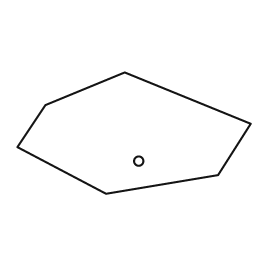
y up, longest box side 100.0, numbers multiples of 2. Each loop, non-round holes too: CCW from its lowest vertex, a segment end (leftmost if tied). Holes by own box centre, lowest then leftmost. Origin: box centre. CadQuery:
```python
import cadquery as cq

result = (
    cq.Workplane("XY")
    .moveTo(-12.0, -26.0)
    .lineTo(36.0, -18.0)
    .lineTo(50.0, 4.0)
    .lineTo(-4.0, 26.0)
    .lineTo(-38.0, 12.0)
    .lineTo(-50.0, -6.0)
    .close()
    .moveTo(2.0, -12.0)
    .circle(2.0)
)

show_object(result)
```